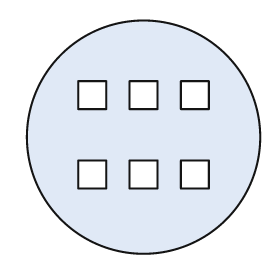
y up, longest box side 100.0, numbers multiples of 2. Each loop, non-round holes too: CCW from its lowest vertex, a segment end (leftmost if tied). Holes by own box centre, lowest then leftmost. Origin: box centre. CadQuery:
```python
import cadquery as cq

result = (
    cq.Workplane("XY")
    .moveTo(0.0, 0.0)
    .circle(50.0)
    .moveTo(-28.0, -22.0)
    .lineTo(-16.0, -22.0)
    .lineTo(-16.0, -10.0)
    .lineTo(-28.0, -10.0)
    .close()
    .moveTo(-6.0, -22.0)
    .lineTo(6.0, -22.0)
    .lineTo(6.0, -10.0)
    .lineTo(-6.0, -10.0)
    .close()
    .moveTo(16.0, -22.0)
    .lineTo(28.0, -22.0)
    .lineTo(28.0, -10.0)
    .lineTo(16.0, -10.0)
    .close()
    .moveTo(-28.0, 12.0)
    .lineTo(-16.0, 12.0)
    .lineTo(-16.0, 24.0)
    .lineTo(-28.0, 24.0)
    .close()
    .moveTo(-6.0, 12.0)
    .lineTo(6.0, 12.0)
    .lineTo(6.0, 24.0)
    .lineTo(-6.0, 24.0)
    .close()
    .moveTo(16.0, 12.0)
    .lineTo(28.0, 12.0)
    .lineTo(28.0, 24.0)
    .lineTo(16.0, 24.0)
    .close()
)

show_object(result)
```